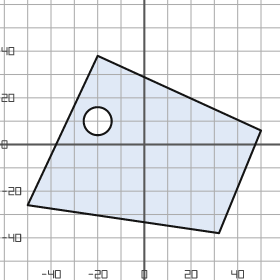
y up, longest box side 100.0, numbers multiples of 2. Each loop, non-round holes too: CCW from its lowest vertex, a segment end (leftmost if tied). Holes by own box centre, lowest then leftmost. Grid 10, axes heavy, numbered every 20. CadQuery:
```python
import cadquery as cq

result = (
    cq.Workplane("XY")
    .moveTo(32.0, -38.0)
    .lineTo(50.0, 6.0)
    .lineTo(-20.0, 38.0)
    .lineTo(-50.0, -26.0)
    .close()
    .moveTo(-20.0, 10.0)
    .circle(6.0)
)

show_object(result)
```